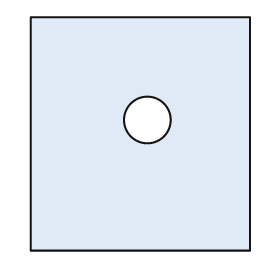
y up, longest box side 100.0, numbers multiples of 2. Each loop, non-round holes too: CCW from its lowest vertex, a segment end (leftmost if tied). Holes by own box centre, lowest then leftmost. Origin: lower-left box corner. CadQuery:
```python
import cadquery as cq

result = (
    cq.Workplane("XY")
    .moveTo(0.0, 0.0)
    .lineTo(94.0, 0.0)
    .lineTo(94.0, 100.0)
    .lineTo(0.0, 100.0)
    .close()
    .moveTo(50.0, 56.0)
    .circle(10.0)
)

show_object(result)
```